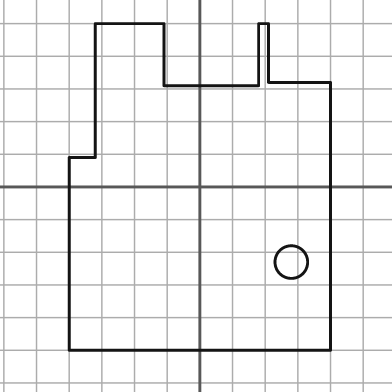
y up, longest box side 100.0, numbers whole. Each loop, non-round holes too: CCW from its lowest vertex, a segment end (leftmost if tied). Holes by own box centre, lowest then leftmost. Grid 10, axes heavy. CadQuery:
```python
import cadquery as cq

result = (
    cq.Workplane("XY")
    .moveTo(-40.0, -50.0)
    .lineTo(40.0, -50.0)
    .lineTo(40.0, 32.0)
    .lineTo(21.0, 32.0)
    .lineTo(21.0, 50.0)
    .lineTo(18.0, 50.0)
    .lineTo(18.0, 31.0)
    .lineTo(-11.0, 31.0)
    .lineTo(-11.0, 50.0)
    .lineTo(-32.0, 50.0)
    .lineTo(-32.0, 9.0)
    .lineTo(-40.0, 9.0)
    .close()
    .moveTo(28.0, -23.0)
    .circle(5.0)
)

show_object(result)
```